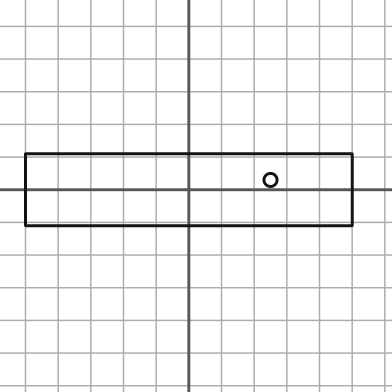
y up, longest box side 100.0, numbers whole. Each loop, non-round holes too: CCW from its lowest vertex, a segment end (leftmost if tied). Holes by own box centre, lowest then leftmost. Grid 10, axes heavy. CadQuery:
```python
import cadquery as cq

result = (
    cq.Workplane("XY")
    .moveTo(-50.0, -11.0)
    .lineTo(50.0, -11.0)
    .lineTo(50.0, 11.0)
    .lineTo(-50.0, 11.0)
    .close()
    .moveTo(25.0, 3.0)
    .circle(2.0)
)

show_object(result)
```